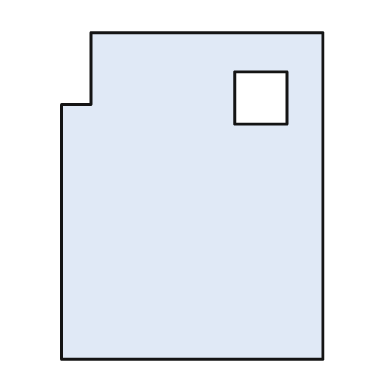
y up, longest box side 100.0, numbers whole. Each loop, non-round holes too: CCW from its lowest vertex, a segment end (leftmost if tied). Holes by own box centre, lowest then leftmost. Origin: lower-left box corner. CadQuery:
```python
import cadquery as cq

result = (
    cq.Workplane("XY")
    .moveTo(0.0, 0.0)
    .lineTo(80.0, 0.0)
    .lineTo(80.0, 100.0)
    .lineTo(9.0, 100.0)
    .lineTo(9.0, 78.0)
    .lineTo(0.0, 78.0)
    .close()
    .moveTo(53.0, 72.0)
    .lineTo(69.0, 72.0)
    .lineTo(69.0, 88.0)
    .lineTo(53.0, 88.0)
    .close()
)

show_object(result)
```